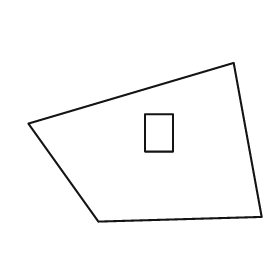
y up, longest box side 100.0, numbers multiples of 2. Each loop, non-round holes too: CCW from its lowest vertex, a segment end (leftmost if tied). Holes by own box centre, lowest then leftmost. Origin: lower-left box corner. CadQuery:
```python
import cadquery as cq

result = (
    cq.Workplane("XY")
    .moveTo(30.0, 0.0)
    .lineTo(100.0, 2.0)
    .lineTo(88.0, 68.0)
    .lineTo(0.0, 42.0)
    .close()
    .moveTo(50.0, 30.0)
    .lineTo(62.0, 30.0)
    .lineTo(62.0, 46.0)
    .lineTo(50.0, 46.0)
    .close()
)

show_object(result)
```